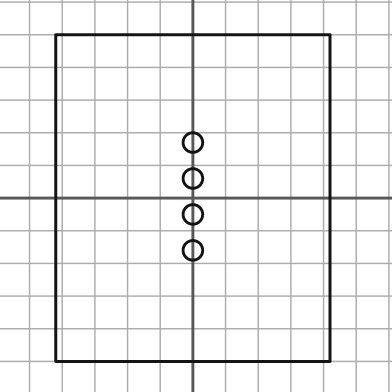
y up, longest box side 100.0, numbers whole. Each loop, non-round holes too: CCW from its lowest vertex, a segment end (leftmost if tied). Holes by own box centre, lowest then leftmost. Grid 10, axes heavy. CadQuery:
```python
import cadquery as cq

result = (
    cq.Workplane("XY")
    .moveTo(-42.0, -50.0)
    .lineTo(42.0, -50.0)
    .lineTo(42.0, 50.0)
    .lineTo(-42.0, 50.0)
    .close()
    .moveTo(0.0, -16.0)
    .circle(3.0)
    .moveTo(0.0, -5.0)
    .circle(3.0)
    .moveTo(0.0, 6.0)
    .circle(3.0)
    .moveTo(0.0, 17.0)
    .circle(3.0)
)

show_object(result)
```